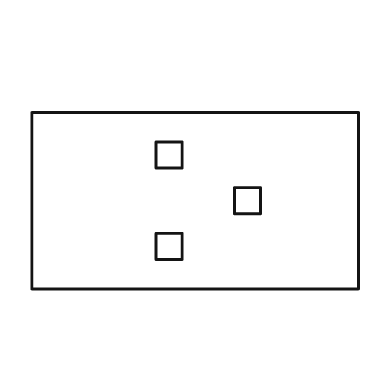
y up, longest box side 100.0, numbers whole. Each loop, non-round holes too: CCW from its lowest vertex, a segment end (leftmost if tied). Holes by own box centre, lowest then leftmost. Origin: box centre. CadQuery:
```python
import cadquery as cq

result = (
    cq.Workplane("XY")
    .moveTo(-50.0, -27.0)
    .lineTo(50.0, -27.0)
    .lineTo(50.0, 27.0)
    .lineTo(-50.0, 27.0)
    .close()
    .moveTo(-12.0, -18.0)
    .lineTo(-4.0, -18.0)
    .lineTo(-4.0, -10.0)
    .lineTo(-12.0, -10.0)
    .close()
    .moveTo(12.0, -4.0)
    .lineTo(20.0, -4.0)
    .lineTo(20.0, 4.0)
    .lineTo(12.0, 4.0)
    .close()
    .moveTo(-12.0, 10.0)
    .lineTo(-4.0, 10.0)
    .lineTo(-4.0, 18.0)
    .lineTo(-12.0, 18.0)
    .close()
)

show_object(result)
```